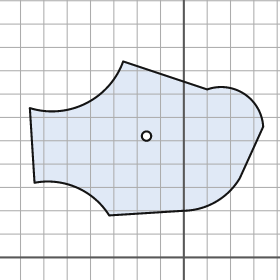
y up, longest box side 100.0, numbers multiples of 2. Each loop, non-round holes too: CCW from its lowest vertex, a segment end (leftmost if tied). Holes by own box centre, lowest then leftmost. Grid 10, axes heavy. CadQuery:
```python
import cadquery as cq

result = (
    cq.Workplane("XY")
    .moveTo(-32.0, 18.0)
    .lineTo(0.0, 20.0)
    .threePointArc((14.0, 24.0), (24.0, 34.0))
    .lineTo(34.0, 56.0)
    .threePointArc((26.0, 70.0), (10.0, 72.0))
    .lineTo(-26.0, 84.0)
    .threePointArc((-42.0, 66.0), (-66.0, 64.0))
    .lineTo(-64.0, 32.0)
    .threePointArc((-46.0, 30.0), (-32.0, 18.0))
    .close()
    .moveTo(-16.0, 52.0)
    .circle(2.0)
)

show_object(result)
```